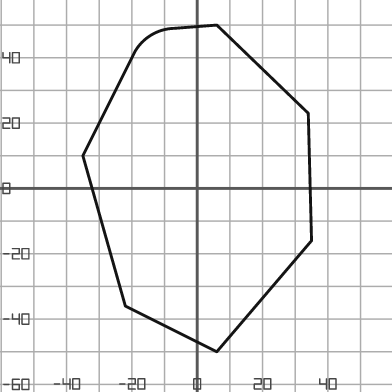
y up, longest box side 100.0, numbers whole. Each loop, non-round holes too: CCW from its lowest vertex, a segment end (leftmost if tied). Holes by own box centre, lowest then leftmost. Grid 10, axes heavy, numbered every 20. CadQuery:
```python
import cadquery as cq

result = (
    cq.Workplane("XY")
    .moveTo(6.0, -50.0)
    .lineTo(35.0, -16.0)
    .lineTo(34.0, 23.0)
    .lineTo(6.0, 50.0)
    .lineTo(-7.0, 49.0)
    .threePointArc((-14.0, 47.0), (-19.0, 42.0))
    .lineTo(-35.0, 10.0)
    .lineTo(-22.0, -36.0)
    .close()
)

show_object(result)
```